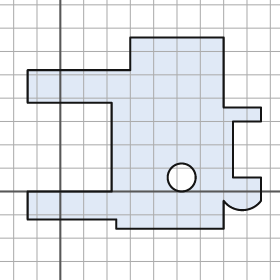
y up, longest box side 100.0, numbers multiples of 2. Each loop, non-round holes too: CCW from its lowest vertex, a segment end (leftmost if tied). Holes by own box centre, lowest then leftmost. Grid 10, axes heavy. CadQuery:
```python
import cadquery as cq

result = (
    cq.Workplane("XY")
    .moveTo(24.0, -16.0)
    .lineTo(70.0, -16.0)
    .lineTo(70.0, -4.0)
    .threePointArc((78.0, -8.0), (86.0, -4.0))
    .lineTo(86.0, 6.0)
    .lineTo(74.0, 6.0)
    .lineTo(74.0, 30.0)
    .lineTo(86.0, 30.0)
    .lineTo(86.0, 36.0)
    .lineTo(70.0, 36.0)
    .lineTo(70.0, 66.0)
    .lineTo(30.0, 66.0)
    .lineTo(30.0, 52.0)
    .lineTo(-14.0, 52.0)
    .lineTo(-14.0, 38.0)
    .lineTo(22.0, 38.0)
    .lineTo(22.0, 0.0)
    .lineTo(-14.0, 0.0)
    .lineTo(-14.0, -12.0)
    .lineTo(24.0, -12.0)
    .close()
    .moveTo(52.0, 6.0)
    .circle(6.0)
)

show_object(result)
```